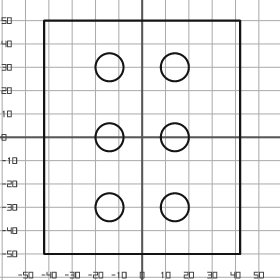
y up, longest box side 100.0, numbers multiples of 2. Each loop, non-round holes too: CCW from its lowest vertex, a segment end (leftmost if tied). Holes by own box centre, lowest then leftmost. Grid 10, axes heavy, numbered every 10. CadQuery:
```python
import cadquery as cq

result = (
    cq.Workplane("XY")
    .moveTo(-42.0, -50.0)
    .lineTo(42.0, -50.0)
    .lineTo(42.0, 50.0)
    .lineTo(-42.0, 50.0)
    .close()
    .moveTo(-14.0, -30.0)
    .circle(6.0)
    .moveTo(14.0, -30.0)
    .circle(6.0)
    .moveTo(-14.0, 0.0)
    .circle(6.0)
    .moveTo(14.0, 0.0)
    .circle(6.0)
    .moveTo(-14.0, 30.0)
    .circle(6.0)
    .moveTo(14.0, 30.0)
    .circle(6.0)
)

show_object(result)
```